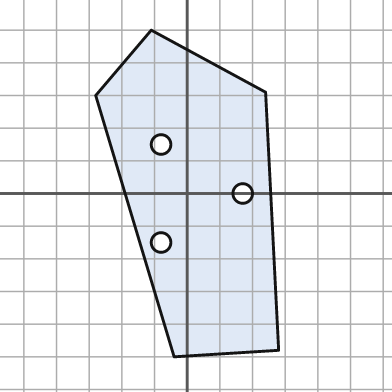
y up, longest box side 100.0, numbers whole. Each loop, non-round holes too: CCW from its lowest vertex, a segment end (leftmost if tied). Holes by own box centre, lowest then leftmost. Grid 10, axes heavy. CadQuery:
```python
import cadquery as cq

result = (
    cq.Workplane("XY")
    .moveTo(-4.0, -50.0)
    .lineTo(28.0, -48.0)
    .lineTo(24.0, 31.0)
    .lineTo(-11.0, 50.0)
    .lineTo(-28.0, 30.0)
    .close()
    .moveTo(-8.0, -15.0)
    .circle(3.0)
    .moveTo(17.0, 0.0)
    .circle(3.0)
    .moveTo(-8.0, 15.0)
    .circle(3.0)
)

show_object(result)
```